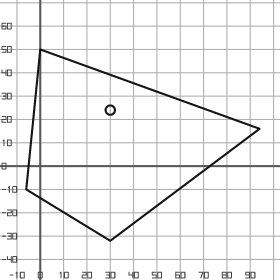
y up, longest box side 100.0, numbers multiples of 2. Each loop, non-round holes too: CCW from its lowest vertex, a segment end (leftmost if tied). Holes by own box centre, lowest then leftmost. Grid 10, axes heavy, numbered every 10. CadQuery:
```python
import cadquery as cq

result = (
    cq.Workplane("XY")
    .moveTo(30.0, -32.0)
    .lineTo(94.0, 16.0)
    .lineTo(0.0, 50.0)
    .lineTo(-6.0, -10.0)
    .close()
    .moveTo(30.0, 24.0)
    .circle(2.0)
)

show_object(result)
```